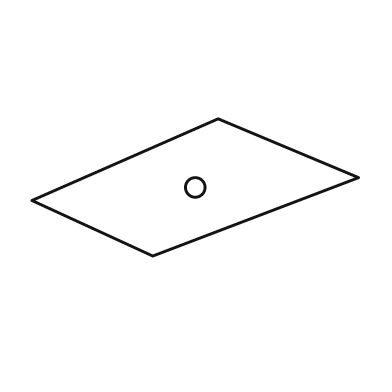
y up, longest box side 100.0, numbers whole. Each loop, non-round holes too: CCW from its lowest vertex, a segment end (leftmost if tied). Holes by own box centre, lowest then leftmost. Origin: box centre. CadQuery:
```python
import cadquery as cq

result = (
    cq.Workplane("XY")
    .moveTo(-13.0, -21.0)
    .lineTo(50.0, 3.0)
    .lineTo(7.0, 21.0)
    .lineTo(-50.0, -4.0)
    .close()
    .moveTo(0.0, 0.0)
    .circle(3.0)
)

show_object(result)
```